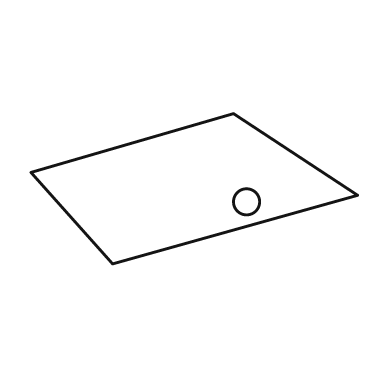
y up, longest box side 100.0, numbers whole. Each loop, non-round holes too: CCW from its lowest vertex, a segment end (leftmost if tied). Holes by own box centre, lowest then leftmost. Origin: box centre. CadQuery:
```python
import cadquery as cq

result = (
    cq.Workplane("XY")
    .moveTo(-25.0, -23.0)
    .lineTo(50.0, -2.0)
    .lineTo(12.0, 23.0)
    .lineTo(-50.0, 5.0)
    .close()
    .moveTo(16.0, -4.0)
    .circle(4.0)
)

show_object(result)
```